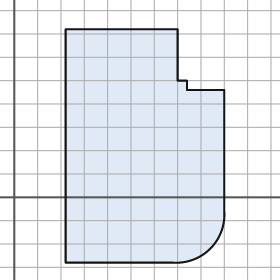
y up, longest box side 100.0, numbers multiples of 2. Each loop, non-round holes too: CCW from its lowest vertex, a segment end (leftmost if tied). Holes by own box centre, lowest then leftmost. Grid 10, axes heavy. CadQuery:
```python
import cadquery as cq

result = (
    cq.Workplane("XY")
    .moveTo(22.0, -28.0)
    .lineTo(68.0, -28.0)
    .threePointArc((84.0, -22.0), (90.0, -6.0))
    .lineTo(90.0, 46.0)
    .lineTo(74.0, 46.0)
    .lineTo(74.0, 50.0)
    .lineTo(70.0, 50.0)
    .lineTo(70.0, 72.0)
    .lineTo(22.0, 72.0)
    .close()
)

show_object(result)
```